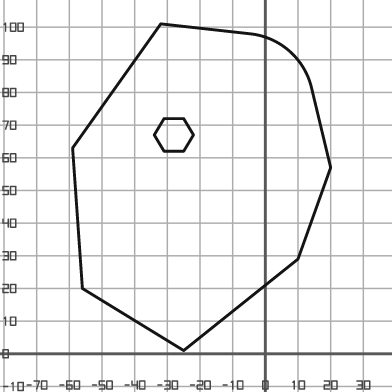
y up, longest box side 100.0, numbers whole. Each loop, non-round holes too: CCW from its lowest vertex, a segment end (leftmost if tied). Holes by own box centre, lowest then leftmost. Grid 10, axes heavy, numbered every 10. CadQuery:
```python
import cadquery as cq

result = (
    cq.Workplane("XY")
    .moveTo(-25.0, 1.0)
    .lineTo(10.0, 29.0)
    .lineTo(20.0, 57.0)
    .lineTo(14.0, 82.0)
    .threePointArc((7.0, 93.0), (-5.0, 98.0))
    .lineTo(-32.0, 101.0)
    .lineTo(-59.0, 63.0)
    .lineTo(-56.0, 20.0)
    .close()
    .moveTo(-31.0, 62.0)
    .lineTo(-25.0, 62.0)
    .lineTo(-22.0, 67.0)
    .lineTo(-25.0, 72.0)
    .lineTo(-31.0, 72.0)
    .lineTo(-34.0, 67.0)
    .close()
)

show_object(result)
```